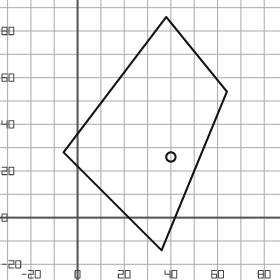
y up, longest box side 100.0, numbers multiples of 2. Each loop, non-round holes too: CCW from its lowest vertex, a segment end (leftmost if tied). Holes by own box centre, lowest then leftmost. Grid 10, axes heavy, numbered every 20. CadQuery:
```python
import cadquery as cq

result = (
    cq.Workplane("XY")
    .moveTo(36.0, -14.0)
    .lineTo(64.0, 54.0)
    .lineTo(38.0, 86.0)
    .lineTo(-6.0, 28.0)
    .close()
    .moveTo(40.0, 26.0)
    .circle(2.0)
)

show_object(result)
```